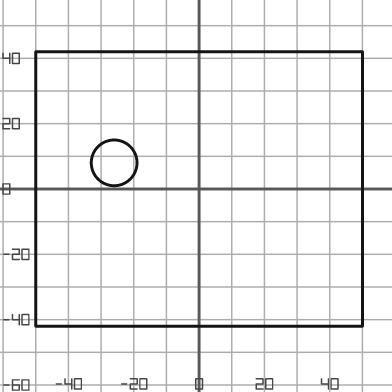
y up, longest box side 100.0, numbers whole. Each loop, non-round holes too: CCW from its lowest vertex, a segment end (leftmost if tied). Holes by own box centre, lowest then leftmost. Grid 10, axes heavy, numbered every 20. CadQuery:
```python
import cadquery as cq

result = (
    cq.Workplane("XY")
    .moveTo(-50.0, -42.0)
    .lineTo(50.0, -42.0)
    .lineTo(50.0, 42.0)
    .lineTo(-50.0, 42.0)
    .close()
    .moveTo(-26.0, 8.0)
    .circle(7.0)
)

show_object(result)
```